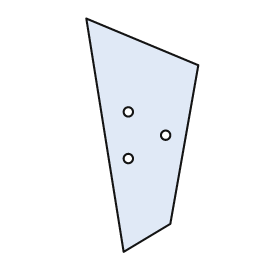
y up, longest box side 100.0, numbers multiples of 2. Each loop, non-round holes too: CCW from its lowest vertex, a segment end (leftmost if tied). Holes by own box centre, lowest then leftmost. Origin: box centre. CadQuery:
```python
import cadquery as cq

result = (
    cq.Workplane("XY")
    .moveTo(-8.0, -50.0)
    .lineTo(12.0, -38.0)
    .lineTo(24.0, 30.0)
    .lineTo(-24.0, 50.0)
    .close()
    .moveTo(-6.0, -10.0)
    .circle(2.0)
    .moveTo(10.0, 0.0)
    .circle(2.0)
    .moveTo(-6.0, 10.0)
    .circle(2.0)
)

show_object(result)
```